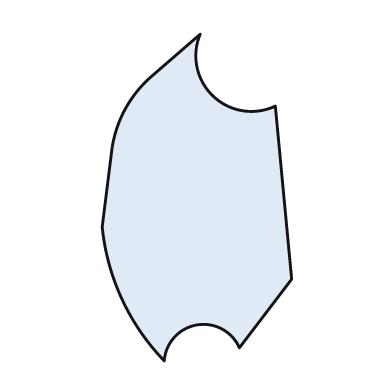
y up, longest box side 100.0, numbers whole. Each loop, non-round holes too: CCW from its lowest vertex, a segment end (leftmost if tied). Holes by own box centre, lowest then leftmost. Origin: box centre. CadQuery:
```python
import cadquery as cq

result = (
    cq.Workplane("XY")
    .moveTo(-10.0, -50.0)
    .threePointArc((0.0, -39.0), (13.0, -46.0))
    .lineTo(29.0, -25.0)
    .lineTo(24.0, 28.0)
    .threePointArc((5.0, 31.0), (1.0, 50.0))
    .lineTo(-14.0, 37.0)
    .threePointArc((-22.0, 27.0), (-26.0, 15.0))
    .lineTo(-29.0, -9.0)
    .threePointArc((-23.0, -31.0), (-10.0, -50.0))
    .close()
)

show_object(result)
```